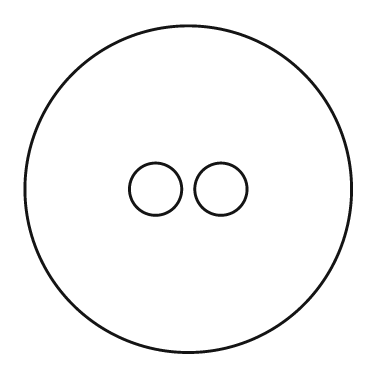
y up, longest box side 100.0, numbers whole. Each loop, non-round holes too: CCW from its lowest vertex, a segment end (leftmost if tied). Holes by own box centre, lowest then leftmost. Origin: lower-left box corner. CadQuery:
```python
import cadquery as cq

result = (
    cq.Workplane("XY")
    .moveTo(50.0, 50.0)
    .circle(50.0)
    .moveTo(40.0, 50.0)
    .circle(8.0)
    .moveTo(60.0, 50.0)
    .circle(8.0)
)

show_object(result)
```